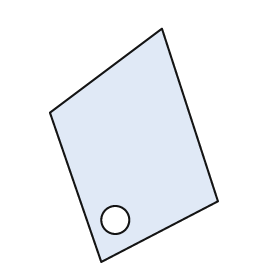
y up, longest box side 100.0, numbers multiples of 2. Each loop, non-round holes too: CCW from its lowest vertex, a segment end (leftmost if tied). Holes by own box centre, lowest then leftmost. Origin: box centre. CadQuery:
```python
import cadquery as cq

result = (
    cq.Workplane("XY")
    .moveTo(-14.0, -50.0)
    .lineTo(36.0, -24.0)
    .lineTo(12.0, 50.0)
    .lineTo(-36.0, 14.0)
    .close()
    .moveTo(-8.0, -32.0)
    .circle(6.0)
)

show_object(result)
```